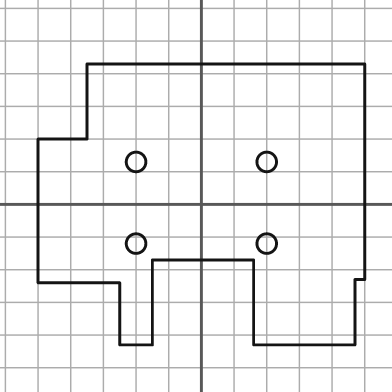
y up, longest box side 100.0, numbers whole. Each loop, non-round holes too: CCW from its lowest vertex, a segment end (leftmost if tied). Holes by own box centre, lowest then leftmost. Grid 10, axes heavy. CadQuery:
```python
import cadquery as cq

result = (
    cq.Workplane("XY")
    .moveTo(-25.0, -43.0)
    .lineTo(-15.0, -43.0)
    .lineTo(-15.0, -17.0)
    .lineTo(16.0, -17.0)
    .lineTo(16.0, -43.0)
    .lineTo(47.0, -43.0)
    .lineTo(47.0, -23.0)
    .lineTo(50.0, -23.0)
    .lineTo(50.0, 43.0)
    .lineTo(-35.0, 43.0)
    .lineTo(-35.0, 20.0)
    .lineTo(-50.0, 20.0)
    .lineTo(-50.0, -24.0)
    .lineTo(-25.0, -24.0)
    .close()
    .moveTo(-20.0, -12.0)
    .circle(3.0)
    .moveTo(20.0, -12.0)
    .circle(3.0)
    .moveTo(-20.0, 13.0)
    .circle(3.0)
    .moveTo(20.0, 13.0)
    .circle(3.0)
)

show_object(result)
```